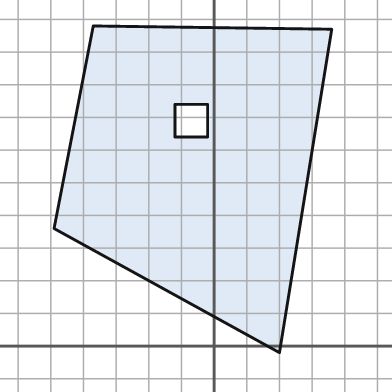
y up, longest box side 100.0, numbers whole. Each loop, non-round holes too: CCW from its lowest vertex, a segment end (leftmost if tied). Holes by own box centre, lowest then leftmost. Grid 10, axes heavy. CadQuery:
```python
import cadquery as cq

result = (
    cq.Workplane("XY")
    .moveTo(20.0, -2.0)
    .lineTo(36.0, 97.0)
    .lineTo(-37.0, 98.0)
    .lineTo(-49.0, 36.0)
    .close()
    .moveTo(-12.0, 64.0)
    .lineTo(-2.0, 64.0)
    .lineTo(-2.0, 74.0)
    .lineTo(-12.0, 74.0)
    .close()
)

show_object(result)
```